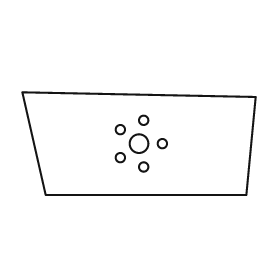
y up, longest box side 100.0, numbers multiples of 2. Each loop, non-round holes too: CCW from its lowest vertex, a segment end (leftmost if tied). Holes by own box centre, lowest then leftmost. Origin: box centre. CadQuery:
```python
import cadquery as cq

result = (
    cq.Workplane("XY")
    .moveTo(-40.0, -22.0)
    .lineTo(46.0, -22.0)
    .lineTo(50.0, 20.0)
    .lineTo(-50.0, 22.0)
    .close()
    .moveTo(2.0, -10.0)
    .circle(2.0)
    .moveTo(-8.0, -6.0)
    .circle(2.0)
    .moveTo(0.0, 0.0)
    .circle(4.0)
    .moveTo(10.0, 0.0)
    .circle(2.0)
    .moveTo(-8.0, 6.0)
    .circle(2.0)
    .moveTo(2.0, 10.0)
    .circle(2.0)
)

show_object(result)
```